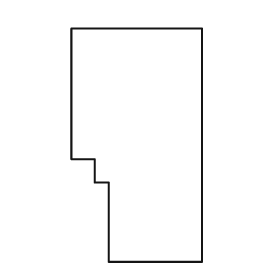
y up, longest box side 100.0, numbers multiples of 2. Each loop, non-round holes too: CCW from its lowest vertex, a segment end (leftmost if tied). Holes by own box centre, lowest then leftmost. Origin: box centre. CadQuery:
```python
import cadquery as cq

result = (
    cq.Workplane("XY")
    .moveTo(-12.0, -50.0)
    .lineTo(28.0, -50.0)
    .lineTo(28.0, 50.0)
    .lineTo(-28.0, 50.0)
    .lineTo(-28.0, -6.0)
    .lineTo(-18.0, -6.0)
    .lineTo(-18.0, -16.0)
    .lineTo(-12.0, -16.0)
    .close()
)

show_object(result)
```